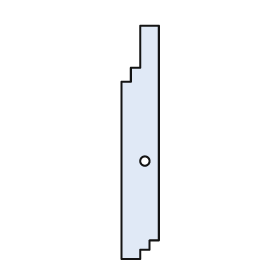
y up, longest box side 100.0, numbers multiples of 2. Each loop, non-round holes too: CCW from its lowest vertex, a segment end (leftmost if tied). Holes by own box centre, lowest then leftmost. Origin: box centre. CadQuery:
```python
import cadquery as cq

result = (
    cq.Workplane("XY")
    .moveTo(-8.0, -50.0)
    .lineTo(0.0, -50.0)
    .lineTo(0.0, -46.0)
    .lineTo(4.0, -46.0)
    .lineTo(4.0, -42.0)
    .lineTo(8.0, -42.0)
    .lineTo(8.0, 50.0)
    .lineTo(0.0, 50.0)
    .lineTo(0.0, 32.0)
    .lineTo(-4.0, 32.0)
    .lineTo(-4.0, 26.0)
    .lineTo(-8.0, 26.0)
    .close()
    .moveTo(2.0, -8.0)
    .circle(2.0)
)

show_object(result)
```